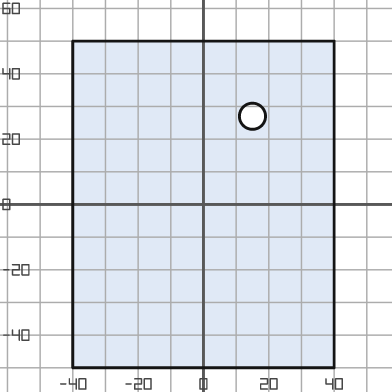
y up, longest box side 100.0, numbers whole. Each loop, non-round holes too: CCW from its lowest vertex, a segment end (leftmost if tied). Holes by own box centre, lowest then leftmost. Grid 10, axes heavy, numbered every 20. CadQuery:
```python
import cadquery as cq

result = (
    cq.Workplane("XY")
    .moveTo(-40.0, -50.0)
    .lineTo(40.0, -50.0)
    .lineTo(40.0, 50.0)
    .lineTo(-40.0, 50.0)
    .close()
    .moveTo(15.0, 27.0)
    .circle(4.0)
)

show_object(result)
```